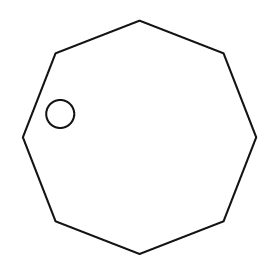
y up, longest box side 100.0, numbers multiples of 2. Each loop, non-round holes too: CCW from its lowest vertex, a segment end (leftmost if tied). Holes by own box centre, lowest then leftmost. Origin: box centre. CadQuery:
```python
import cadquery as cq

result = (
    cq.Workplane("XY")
    .moveTo(0.0, -50.0)
    .lineTo(36.0, -36.0)
    .lineTo(50.0, 0.0)
    .lineTo(36.0, 36.0)
    .lineTo(0.0, 50.0)
    .lineTo(-36.0, 36.0)
    .lineTo(-50.0, 0.0)
    .lineTo(-36.0, -36.0)
    .close()
    .moveTo(-34.0, 10.0)
    .circle(6.0)
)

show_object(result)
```